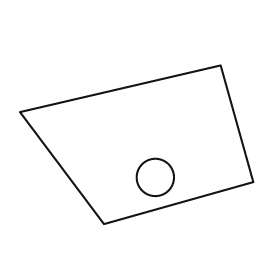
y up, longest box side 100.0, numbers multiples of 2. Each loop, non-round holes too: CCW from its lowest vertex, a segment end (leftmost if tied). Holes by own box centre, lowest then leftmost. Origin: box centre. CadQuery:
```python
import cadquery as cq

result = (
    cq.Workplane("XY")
    .moveTo(-14.0, -34.0)
    .lineTo(50.0, -16.0)
    .lineTo(36.0, 34.0)
    .lineTo(-50.0, 14.0)
    .close()
    .moveTo(8.0, -14.0)
    .circle(8.0)
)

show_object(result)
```